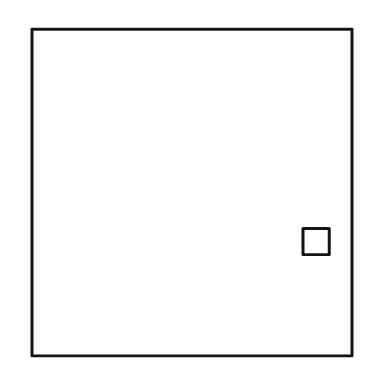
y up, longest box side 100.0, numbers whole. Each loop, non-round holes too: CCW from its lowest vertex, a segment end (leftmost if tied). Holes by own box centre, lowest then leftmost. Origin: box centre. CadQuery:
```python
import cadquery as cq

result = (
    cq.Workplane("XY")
    .moveTo(-49.0, -50.0)
    .lineTo(49.0, -50.0)
    .lineTo(49.0, 50.0)
    .lineTo(-49.0, 50.0)
    .close()
    .moveTo(34.0, -19.0)
    .lineTo(42.0, -19.0)
    .lineTo(42.0, -11.0)
    .lineTo(34.0, -11.0)
    .close()
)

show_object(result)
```